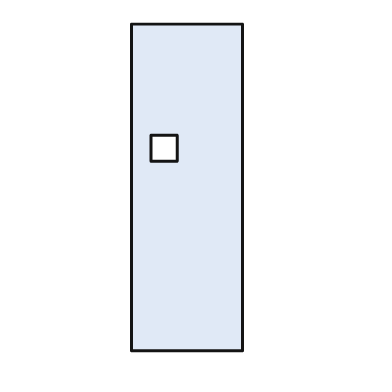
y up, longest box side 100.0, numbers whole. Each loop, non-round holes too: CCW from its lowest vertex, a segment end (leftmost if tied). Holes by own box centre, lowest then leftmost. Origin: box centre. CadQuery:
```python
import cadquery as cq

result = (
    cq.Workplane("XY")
    .moveTo(-17.0, -50.0)
    .lineTo(17.0, -50.0)
    .lineTo(17.0, 50.0)
    .lineTo(-17.0, 50.0)
    .close()
    .moveTo(-11.0, 8.0)
    .lineTo(-3.0, 8.0)
    .lineTo(-3.0, 16.0)
    .lineTo(-11.0, 16.0)
    .close()
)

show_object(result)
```